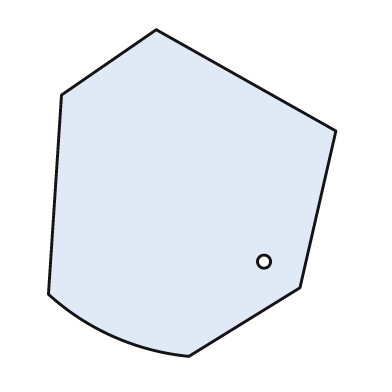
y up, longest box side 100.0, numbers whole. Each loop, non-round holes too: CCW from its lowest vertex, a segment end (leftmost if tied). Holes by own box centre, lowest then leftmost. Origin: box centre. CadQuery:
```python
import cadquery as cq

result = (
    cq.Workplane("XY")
    .moveTo(-1.0, -50.0)
    .lineTo(33.0, -29.0)
    .lineTo(44.0, 19.0)
    .lineTo(-11.0, 50.0)
    .lineTo(-40.0, 30.0)
    .lineTo(-44.0, -31.0)
    .threePointArc((-24.0, -44.0), (-1.0, -50.0))
    .close()
    .moveTo(22.0, -21.0)
    .circle(2.0)
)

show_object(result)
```